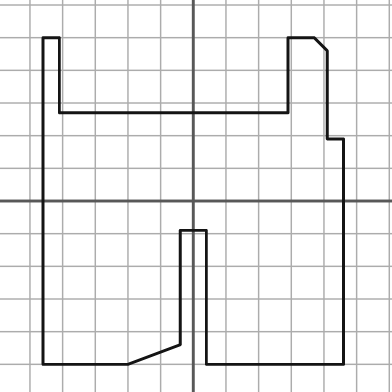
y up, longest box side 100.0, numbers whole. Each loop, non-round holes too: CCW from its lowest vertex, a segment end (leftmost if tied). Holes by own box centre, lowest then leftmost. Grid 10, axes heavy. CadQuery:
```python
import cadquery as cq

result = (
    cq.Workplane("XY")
    .moveTo(-46.0, -50.0)
    .lineTo(-20.0, -50.0)
    .lineTo(-4.0, -44.0)
    .lineTo(-4.0, -9.0)
    .lineTo(4.0, -9.0)
    .lineTo(4.0, -50.0)
    .lineTo(46.0, -50.0)
    .lineTo(46.0, 19.0)
    .lineTo(41.0, 19.0)
    .lineTo(41.0, 46.0)
    .lineTo(37.0, 50.0)
    .lineTo(29.0, 50.0)
    .lineTo(29.0, 27.0)
    .lineTo(-41.0, 27.0)
    .lineTo(-41.0, 50.0)
    .lineTo(-46.0, 50.0)
    .close()
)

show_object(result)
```